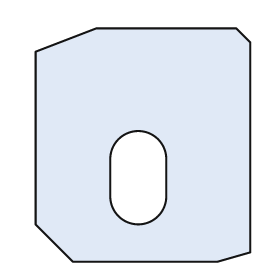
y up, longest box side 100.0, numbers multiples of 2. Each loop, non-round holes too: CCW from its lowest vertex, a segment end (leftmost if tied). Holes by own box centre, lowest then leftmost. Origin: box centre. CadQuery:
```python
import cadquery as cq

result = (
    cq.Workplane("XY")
    .moveTo(-30.0, -50.0)
    .lineTo(32.0, -50.0)
    .lineTo(46.0, -46.0)
    .lineTo(46.0, 44.0)
    .lineTo(40.0, 50.0)
    .lineTo(-20.0, 50.0)
    .lineTo(-46.0, 40.0)
    .lineTo(-46.0, -34.0)
    .close()
    .moveTo(-14.0, -22.0)
    .threePointArc((-2.0, -34.0), (10.0, -22.0))
    .lineTo(10.0, -6.0)
    .threePointArc((-2.0, 6.0), (-14.0, -6.0))
    .close()
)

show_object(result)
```